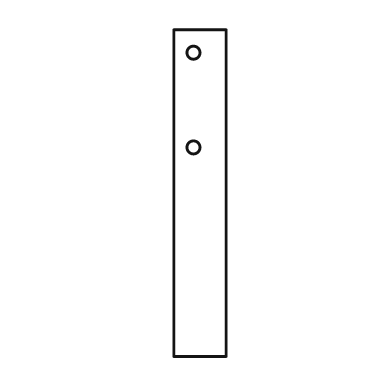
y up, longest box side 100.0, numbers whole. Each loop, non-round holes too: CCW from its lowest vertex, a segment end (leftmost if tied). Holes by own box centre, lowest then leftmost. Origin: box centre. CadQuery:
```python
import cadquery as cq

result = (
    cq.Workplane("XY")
    .moveTo(-8.0, -50.0)
    .lineTo(8.0, -50.0)
    .lineTo(8.0, 50.0)
    .lineTo(-8.0, 50.0)
    .close()
    .moveTo(-2.0, 14.0)
    .circle(2.0)
    .moveTo(-2.0, 43.0)
    .circle(2.0)
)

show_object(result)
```